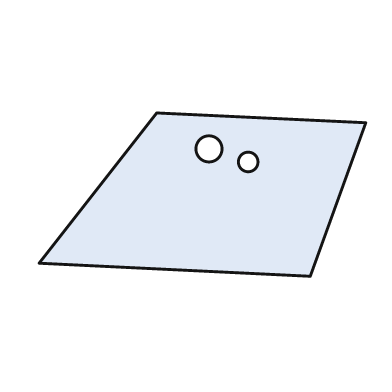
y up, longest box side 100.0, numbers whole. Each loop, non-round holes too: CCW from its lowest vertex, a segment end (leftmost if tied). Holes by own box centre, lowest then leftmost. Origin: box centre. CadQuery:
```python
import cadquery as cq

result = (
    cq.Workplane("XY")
    .moveTo(33.0, -25.0)
    .lineTo(50.0, 22.0)
    .lineTo(-14.0, 25.0)
    .lineTo(-50.0, -21.0)
    .close()
    .moveTo(14.0, 10.0)
    .circle(3.0)
    .moveTo(2.0, 14.0)
    .circle(4.0)
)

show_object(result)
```